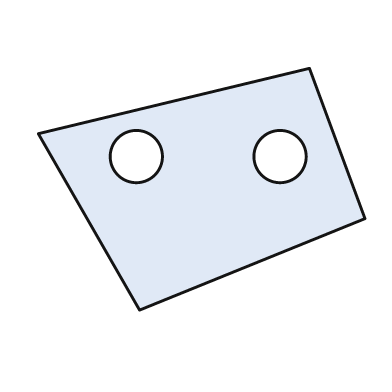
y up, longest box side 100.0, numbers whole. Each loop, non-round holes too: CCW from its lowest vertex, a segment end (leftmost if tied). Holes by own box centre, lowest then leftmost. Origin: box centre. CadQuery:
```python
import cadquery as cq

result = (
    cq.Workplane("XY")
    .moveTo(-19.0, -37.0)
    .lineTo(50.0, -9.0)
    .lineTo(33.0, 37.0)
    .lineTo(-50.0, 17.0)
    .close()
    .moveTo(-20.0, 10.0)
    .circle(8.0)
    .moveTo(24.0, 10.0)
    .circle(8.0)
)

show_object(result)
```